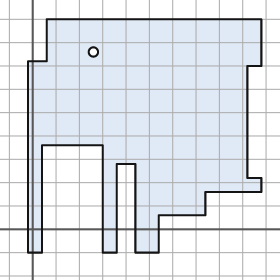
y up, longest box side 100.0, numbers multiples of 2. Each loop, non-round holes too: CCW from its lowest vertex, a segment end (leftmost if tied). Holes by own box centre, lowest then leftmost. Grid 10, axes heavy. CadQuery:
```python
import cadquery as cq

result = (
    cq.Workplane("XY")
    .moveTo(-2.0, -10.0)
    .lineTo(4.0, -10.0)
    .lineTo(4.0, 36.0)
    .lineTo(30.0, 36.0)
    .lineTo(30.0, -10.0)
    .lineTo(36.0, -10.0)
    .lineTo(36.0, 28.0)
    .lineTo(44.0, 28.0)
    .lineTo(44.0, -10.0)
    .lineTo(54.0, -10.0)
    .lineTo(54.0, 6.0)
    .lineTo(74.0, 6.0)
    .lineTo(74.0, 16.0)
    .lineTo(98.0, 16.0)
    .lineTo(98.0, 22.0)
    .lineTo(92.0, 22.0)
    .lineTo(92.0, 70.0)
    .lineTo(98.0, 70.0)
    .lineTo(98.0, 90.0)
    .lineTo(6.0, 90.0)
    .lineTo(6.0, 72.0)
    .lineTo(-2.0, 72.0)
    .close()
    .moveTo(26.0, 76.0)
    .circle(2.0)
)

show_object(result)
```